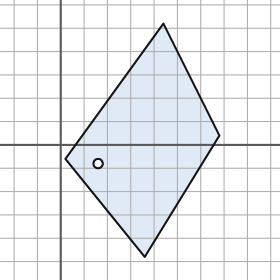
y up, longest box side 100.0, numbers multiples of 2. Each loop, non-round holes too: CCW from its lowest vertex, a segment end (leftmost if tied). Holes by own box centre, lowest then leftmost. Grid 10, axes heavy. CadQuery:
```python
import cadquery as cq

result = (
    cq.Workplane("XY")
    .moveTo(36.0, -48.0)
    .lineTo(68.0, 4.0)
    .lineTo(44.0, 52.0)
    .lineTo(2.0, -6.0)
    .close()
    .moveTo(16.0, -8.0)
    .circle(2.0)
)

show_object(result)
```